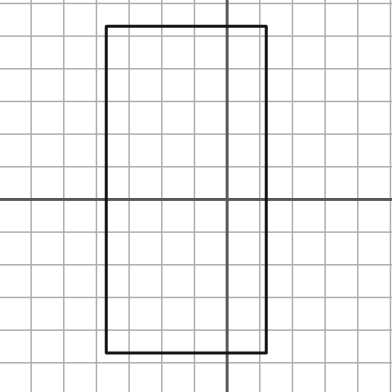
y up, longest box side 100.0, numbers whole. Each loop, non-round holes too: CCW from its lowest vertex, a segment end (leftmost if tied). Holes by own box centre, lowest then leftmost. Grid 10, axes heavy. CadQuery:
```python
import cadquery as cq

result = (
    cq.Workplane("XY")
    .moveTo(-37.0, -47.0)
    .lineTo(12.0, -47.0)
    .lineTo(12.0, 53.0)
    .lineTo(-37.0, 53.0)
    .close()
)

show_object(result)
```